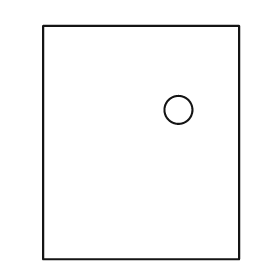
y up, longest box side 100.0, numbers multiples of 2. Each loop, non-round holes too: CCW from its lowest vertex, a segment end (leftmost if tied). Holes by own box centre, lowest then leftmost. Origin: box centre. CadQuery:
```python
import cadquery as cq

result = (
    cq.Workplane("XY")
    .moveTo(-42.0, -50.0)
    .lineTo(42.0, -50.0)
    .lineTo(42.0, 50.0)
    .lineTo(-42.0, 50.0)
    .close()
    .moveTo(16.0, 14.0)
    .circle(6.0)
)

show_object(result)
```